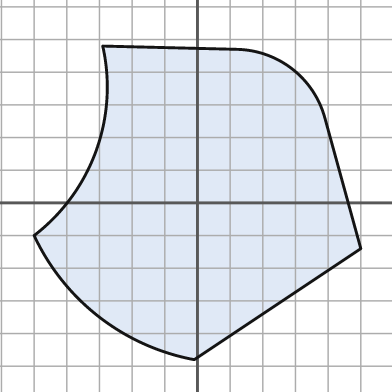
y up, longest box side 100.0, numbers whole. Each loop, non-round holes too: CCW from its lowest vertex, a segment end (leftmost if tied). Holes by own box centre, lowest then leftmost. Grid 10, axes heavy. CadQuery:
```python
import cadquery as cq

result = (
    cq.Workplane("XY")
    .moveTo(-1.0, -48.0)
    .lineTo(50.0, -14.0)
    .lineTo(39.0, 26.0)
    .threePointArc((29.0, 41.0), (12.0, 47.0))
    .lineTo(-29.0, 48.0)
    .threePointArc((-31.0, 16.0), (-50.0, -10.0))
    .threePointArc((-30.0, -35.0), (-1.0, -48.0))
    .close()
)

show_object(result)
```